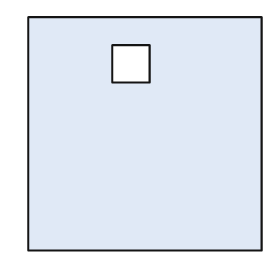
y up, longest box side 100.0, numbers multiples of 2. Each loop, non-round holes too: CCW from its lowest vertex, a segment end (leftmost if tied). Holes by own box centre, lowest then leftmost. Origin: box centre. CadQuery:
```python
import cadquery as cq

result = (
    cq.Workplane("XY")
    .moveTo(-50.0, -50.0)
    .lineTo(50.0, -50.0)
    .lineTo(50.0, 50.0)
    .lineTo(-50.0, 50.0)
    .close()
    .moveTo(-14.0, 22.0)
    .lineTo(2.0, 22.0)
    .lineTo(2.0, 38.0)
    .lineTo(-14.0, 38.0)
    .close()
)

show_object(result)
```